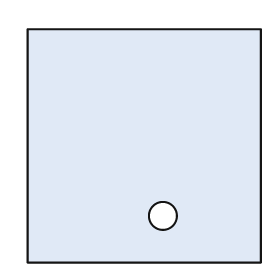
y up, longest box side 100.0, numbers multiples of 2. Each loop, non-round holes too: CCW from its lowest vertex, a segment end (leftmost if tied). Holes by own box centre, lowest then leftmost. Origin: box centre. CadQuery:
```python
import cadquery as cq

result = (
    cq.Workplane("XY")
    .moveTo(-50.0, -50.0)
    .lineTo(50.0, -50.0)
    .lineTo(50.0, 50.0)
    .lineTo(-50.0, 50.0)
    .close()
    .moveTo(8.0, -30.0)
    .circle(6.0)
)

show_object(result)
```